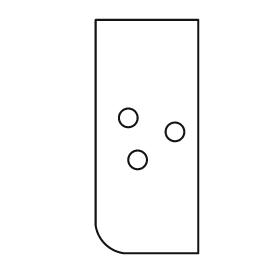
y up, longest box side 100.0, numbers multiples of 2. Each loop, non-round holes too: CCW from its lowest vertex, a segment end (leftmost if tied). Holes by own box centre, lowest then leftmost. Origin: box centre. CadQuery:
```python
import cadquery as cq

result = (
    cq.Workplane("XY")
    .moveTo(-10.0, -50.0)
    .lineTo(22.0, -50.0)
    .lineTo(22.0, 50.0)
    .lineTo(-22.0, 50.0)
    .lineTo(-22.0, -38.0)
    .threePointArc((-18.0, -46.0), (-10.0, -50.0))
    .close()
    .moveTo(-4.0, -10.0)
    .circle(4.0)
    .moveTo(12.0, 2.0)
    .circle(4.0)
    .moveTo(-8.0, 8.0)
    .circle(4.0)
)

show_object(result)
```